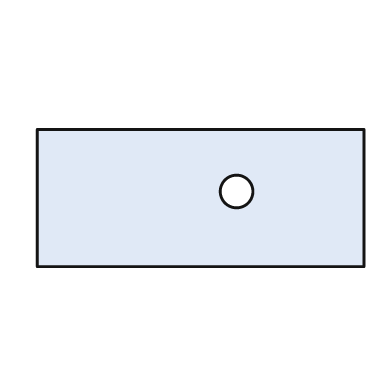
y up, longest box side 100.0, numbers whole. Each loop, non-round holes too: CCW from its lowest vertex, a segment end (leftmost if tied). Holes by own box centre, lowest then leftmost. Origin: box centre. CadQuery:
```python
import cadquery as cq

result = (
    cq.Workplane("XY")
    .moveTo(-50.0, -21.0)
    .lineTo(50.0, -21.0)
    .lineTo(50.0, 21.0)
    .lineTo(-50.0, 21.0)
    .close()
    .moveTo(11.0, 2.0)
    .circle(5.0)
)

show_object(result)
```